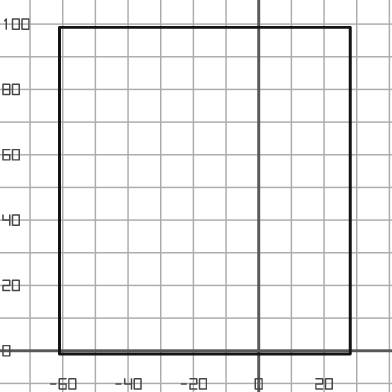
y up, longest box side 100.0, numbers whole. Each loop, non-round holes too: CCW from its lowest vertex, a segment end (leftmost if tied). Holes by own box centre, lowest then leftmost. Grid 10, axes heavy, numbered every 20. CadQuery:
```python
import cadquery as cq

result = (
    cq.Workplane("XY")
    .moveTo(-61.0, -1.0)
    .lineTo(28.0, -1.0)
    .lineTo(28.0, 99.0)
    .lineTo(-61.0, 99.0)
    .close()
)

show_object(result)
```